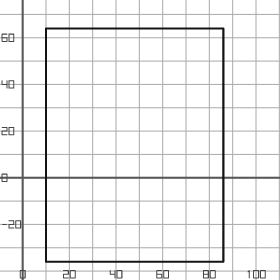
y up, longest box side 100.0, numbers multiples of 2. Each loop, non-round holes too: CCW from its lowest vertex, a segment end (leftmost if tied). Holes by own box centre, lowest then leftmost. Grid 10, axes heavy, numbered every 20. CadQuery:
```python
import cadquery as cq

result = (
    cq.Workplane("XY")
    .moveTo(10.0, -36.0)
    .lineTo(86.0, -36.0)
    .lineTo(86.0, 64.0)
    .lineTo(10.0, 64.0)
    .close()
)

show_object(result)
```